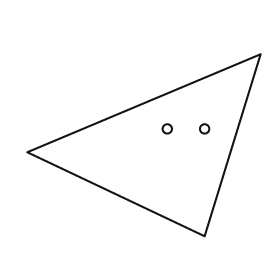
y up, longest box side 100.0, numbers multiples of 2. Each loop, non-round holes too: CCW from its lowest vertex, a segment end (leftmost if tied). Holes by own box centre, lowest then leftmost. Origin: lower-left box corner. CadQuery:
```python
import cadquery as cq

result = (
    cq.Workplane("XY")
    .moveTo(76.0, 0.0)
    .lineTo(100.0, 78.0)
    .lineTo(0.0, 36.0)
    .close()
    .moveTo(60.0, 46.0)
    .circle(2.0)
    .moveTo(76.0, 46.0)
    .circle(2.0)
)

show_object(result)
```